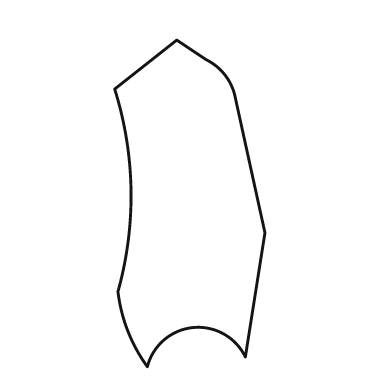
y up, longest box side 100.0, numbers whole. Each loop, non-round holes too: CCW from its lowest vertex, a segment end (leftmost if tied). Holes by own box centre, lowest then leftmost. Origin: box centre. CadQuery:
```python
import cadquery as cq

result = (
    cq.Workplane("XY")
    .moveTo(-13.0, -50.0)
    .threePointArc((1.0, -38.0), (17.0, -47.0))
    .lineTo(23.0, -9.0)
    .lineTo(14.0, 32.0)
    .threePointArc((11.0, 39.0), (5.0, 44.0))
    .lineTo(-4.0, 50.0)
    .lineTo(-23.0, 35.0)
    .threePointArc((-18.0, 4.0), (-22.0, -27.0))
    .threePointArc((-19.0, -39.0), (-13.0, -50.0))
    .close()
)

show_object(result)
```